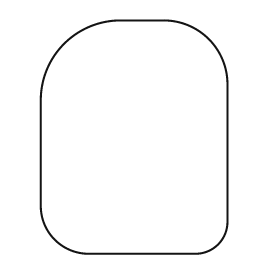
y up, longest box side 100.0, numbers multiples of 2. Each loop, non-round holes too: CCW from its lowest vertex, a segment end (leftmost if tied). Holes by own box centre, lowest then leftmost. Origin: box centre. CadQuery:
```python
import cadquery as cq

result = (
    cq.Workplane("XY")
    .moveTo(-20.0, -50.0)
    .lineTo(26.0, -50.0)
    .threePointArc((36.0, -46.0), (40.0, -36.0))
    .lineTo(40.0, 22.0)
    .threePointArc((32.0, 42.0), (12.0, 50.0))
    .lineTo(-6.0, 50.0)
    .threePointArc((-30.0, 40.0), (-40.0, 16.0))
    .lineTo(-40.0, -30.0)
    .threePointArc((-34.0, -44.0), (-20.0, -50.0))
    .close()
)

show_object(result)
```